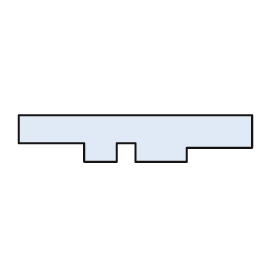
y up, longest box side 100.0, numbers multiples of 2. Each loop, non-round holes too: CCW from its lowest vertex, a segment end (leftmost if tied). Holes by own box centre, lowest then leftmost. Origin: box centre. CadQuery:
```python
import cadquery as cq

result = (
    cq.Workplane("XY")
    .moveTo(-22.0, -10.0)
    .lineTo(-8.0, -10.0)
    .lineTo(-8.0, -2.0)
    .lineTo(0.0, -2.0)
    .lineTo(0.0, -10.0)
    .lineTo(22.0, -10.0)
    .lineTo(22.0, -4.0)
    .lineTo(50.0, -4.0)
    .lineTo(50.0, 10.0)
    .lineTo(-50.0, 10.0)
    .lineTo(-50.0, -2.0)
    .lineTo(-22.0, -2.0)
    .close()
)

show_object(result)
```